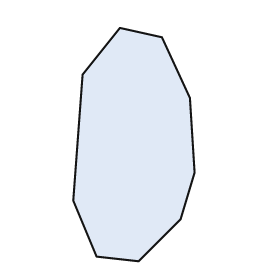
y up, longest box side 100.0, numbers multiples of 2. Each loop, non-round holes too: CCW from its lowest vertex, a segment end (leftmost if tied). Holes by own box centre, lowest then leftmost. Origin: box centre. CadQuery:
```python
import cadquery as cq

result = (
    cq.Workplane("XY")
    .moveTo(2.0, -50.0)
    .lineTo(20.0, -32.0)
    .lineTo(26.0, -12.0)
    .lineTo(24.0, 20.0)
    .lineTo(12.0, 46.0)
    .lineTo(-6.0, 50.0)
    .lineTo(-22.0, 30.0)
    .lineTo(-26.0, -24.0)
    .lineTo(-16.0, -48.0)
    .close()
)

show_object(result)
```